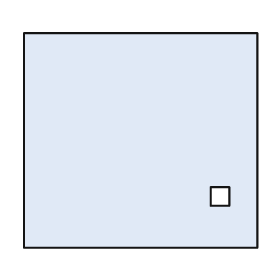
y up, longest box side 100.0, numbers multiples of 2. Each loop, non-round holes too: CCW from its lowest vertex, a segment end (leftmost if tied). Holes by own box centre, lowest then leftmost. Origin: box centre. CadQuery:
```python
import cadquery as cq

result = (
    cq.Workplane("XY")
    .moveTo(-50.0, -46.0)
    .lineTo(50.0, -46.0)
    .lineTo(50.0, 46.0)
    .lineTo(-50.0, 46.0)
    .close()
    .moveTo(30.0, -28.0)
    .lineTo(38.0, -28.0)
    .lineTo(38.0, -20.0)
    .lineTo(30.0, -20.0)
    .close()
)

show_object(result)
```